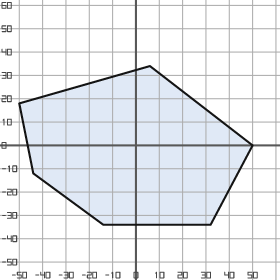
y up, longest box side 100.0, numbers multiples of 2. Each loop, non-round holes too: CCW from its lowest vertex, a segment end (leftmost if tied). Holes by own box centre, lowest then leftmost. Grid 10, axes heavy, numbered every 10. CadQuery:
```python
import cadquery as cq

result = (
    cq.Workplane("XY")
    .moveTo(-14.0, -34.0)
    .lineTo(32.0, -34.0)
    .lineTo(50.0, 0.0)
    .lineTo(6.0, 34.0)
    .lineTo(-50.0, 18.0)
    .lineTo(-44.0, -12.0)
    .close()
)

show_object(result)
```